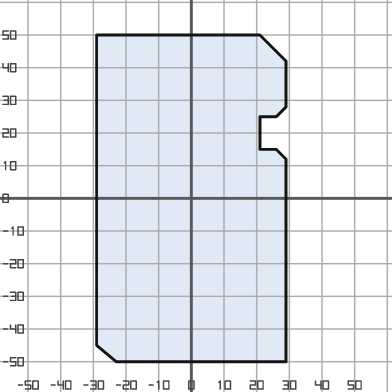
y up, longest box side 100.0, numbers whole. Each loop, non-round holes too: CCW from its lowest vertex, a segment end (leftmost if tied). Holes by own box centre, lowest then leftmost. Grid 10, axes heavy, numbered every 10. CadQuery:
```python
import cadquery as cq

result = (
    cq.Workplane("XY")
    .moveTo(-23.0, -50.0)
    .lineTo(29.0, -50.0)
    .lineTo(29.0, 12.0)
    .lineTo(26.0, 15.0)
    .lineTo(21.0, 15.0)
    .lineTo(21.0, 25.0)
    .lineTo(26.0, 25.0)
    .lineTo(29.0, 28.0)
    .lineTo(29.0, 42.0)
    .lineTo(21.0, 50.0)
    .lineTo(-29.0, 50.0)
    .lineTo(-29.0, -45.0)
    .close()
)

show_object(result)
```